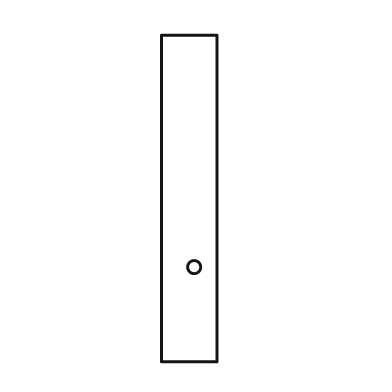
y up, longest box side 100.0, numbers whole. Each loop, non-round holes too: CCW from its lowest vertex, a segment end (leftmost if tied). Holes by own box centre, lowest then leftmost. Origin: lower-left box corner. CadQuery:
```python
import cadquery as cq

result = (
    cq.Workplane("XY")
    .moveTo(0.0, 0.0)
    .lineTo(17.0, 0.0)
    .lineTo(17.0, 100.0)
    .lineTo(0.0, 100.0)
    .close()
    .moveTo(10.0, 29.0)
    .circle(2.0)
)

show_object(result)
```